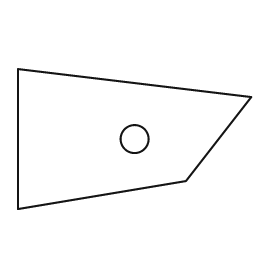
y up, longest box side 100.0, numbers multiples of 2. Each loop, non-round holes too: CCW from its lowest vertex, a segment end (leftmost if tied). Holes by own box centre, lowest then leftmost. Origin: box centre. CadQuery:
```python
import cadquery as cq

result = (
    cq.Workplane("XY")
    .moveTo(-50.0, -30.0)
    .lineTo(22.0, -18.0)
    .lineTo(50.0, 18.0)
    .lineTo(-50.0, 30.0)
    .close()
    .moveTo(0.0, 0.0)
    .circle(6.0)
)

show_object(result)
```